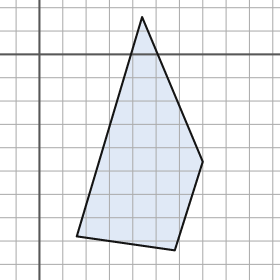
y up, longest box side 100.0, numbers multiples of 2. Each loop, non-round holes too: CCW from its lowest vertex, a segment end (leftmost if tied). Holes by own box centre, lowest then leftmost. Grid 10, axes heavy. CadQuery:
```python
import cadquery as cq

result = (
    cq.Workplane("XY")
    .moveTo(58.0, -84.0)
    .lineTo(70.0, -46.0)
    .lineTo(44.0, 16.0)
    .lineTo(16.0, -78.0)
    .close()
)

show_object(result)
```